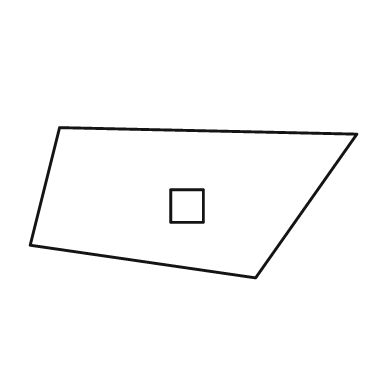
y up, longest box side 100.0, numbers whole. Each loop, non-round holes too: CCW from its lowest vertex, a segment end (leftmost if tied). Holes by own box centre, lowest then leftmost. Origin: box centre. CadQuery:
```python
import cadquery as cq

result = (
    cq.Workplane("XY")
    .moveTo(19.0, -23.0)
    .lineTo(50.0, 21.0)
    .lineTo(-41.0, 23.0)
    .lineTo(-50.0, -13.0)
    .close()
    .moveTo(-7.0, -6.0)
    .lineTo(3.0, -6.0)
    .lineTo(3.0, 4.0)
    .lineTo(-7.0, 4.0)
    .close()
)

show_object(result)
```